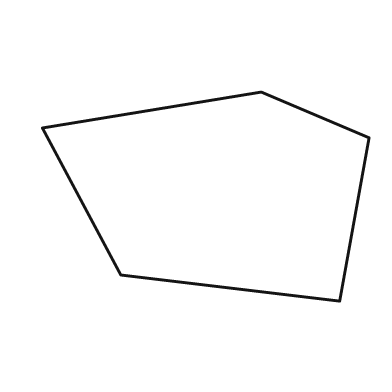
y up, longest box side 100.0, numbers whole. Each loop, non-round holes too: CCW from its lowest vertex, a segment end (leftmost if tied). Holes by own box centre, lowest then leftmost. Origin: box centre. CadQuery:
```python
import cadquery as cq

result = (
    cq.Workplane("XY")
    .moveTo(41.0, -32.0)
    .lineTo(50.0, 18.0)
    .lineTo(17.0, 32.0)
    .lineTo(-50.0, 21.0)
    .lineTo(-26.0, -24.0)
    .close()
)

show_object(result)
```